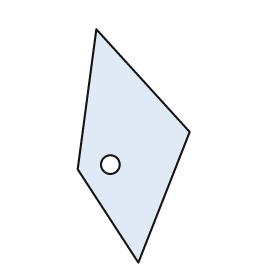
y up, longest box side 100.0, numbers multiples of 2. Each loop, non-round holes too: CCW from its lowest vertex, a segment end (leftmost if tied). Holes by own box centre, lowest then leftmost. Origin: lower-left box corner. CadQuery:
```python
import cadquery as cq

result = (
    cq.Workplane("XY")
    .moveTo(26.0, 0.0)
    .lineTo(48.0, 56.0)
    .lineTo(8.0, 100.0)
    .lineTo(0.0, 40.0)
    .close()
    .moveTo(14.0, 42.0)
    .circle(4.0)
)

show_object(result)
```